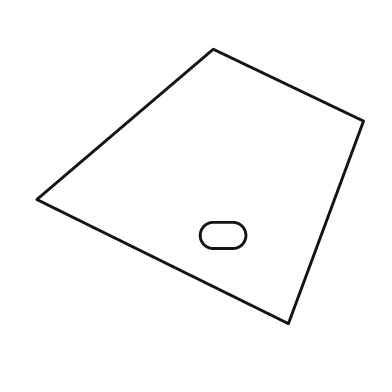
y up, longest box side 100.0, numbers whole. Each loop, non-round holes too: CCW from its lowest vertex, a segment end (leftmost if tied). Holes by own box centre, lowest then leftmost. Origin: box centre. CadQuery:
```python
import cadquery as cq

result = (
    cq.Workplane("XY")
    .moveTo(27.0, -42.0)
    .lineTo(50.0, 20.0)
    .lineTo(4.0, 42.0)
    .lineTo(-50.0, -4.0)
    .close()
    .moveTo(4.0, -19.0)
    .lineTo(10.0, -19.0)
    .threePointArc((14.0, -15.0), (10.0, -11.0))
    .lineTo(4.0, -11.0)
    .threePointArc((0.0, -15.0), (4.0, -19.0))
    .close()
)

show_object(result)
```